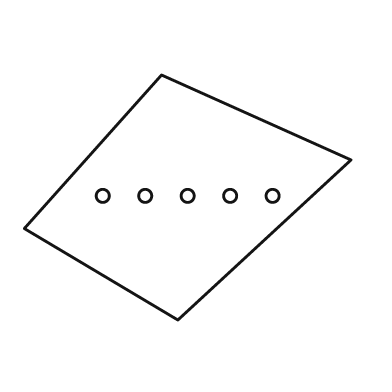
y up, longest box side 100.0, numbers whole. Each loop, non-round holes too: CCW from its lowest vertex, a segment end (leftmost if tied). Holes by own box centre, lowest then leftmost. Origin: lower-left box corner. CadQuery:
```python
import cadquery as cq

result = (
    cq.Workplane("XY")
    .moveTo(47.0, 0.0)
    .lineTo(100.0, 49.0)
    .lineTo(42.0, 75.0)
    .lineTo(0.0, 28.0)
    .close()
    .moveTo(24.0, 38.0)
    .circle(2.0)
    .moveTo(37.0, 38.0)
    .circle(2.0)
    .moveTo(50.0, 38.0)
    .circle(2.0)
    .moveTo(63.0, 38.0)
    .circle(2.0)
    .moveTo(76.0, 38.0)
    .circle(2.0)
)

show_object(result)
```